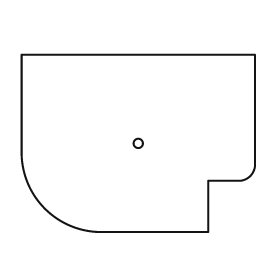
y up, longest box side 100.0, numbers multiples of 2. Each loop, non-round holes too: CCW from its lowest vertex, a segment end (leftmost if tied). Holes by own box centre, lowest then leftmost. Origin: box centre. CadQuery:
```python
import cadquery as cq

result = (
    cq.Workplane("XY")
    .moveTo(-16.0, -38.0)
    .lineTo(30.0, -38.0)
    .lineTo(30.0, -16.0)
    .lineTo(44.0, -16.0)
    .threePointArc((48.0, -14.0), (50.0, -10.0))
    .lineTo(50.0, 38.0)
    .lineTo(-50.0, 38.0)
    .lineTo(-50.0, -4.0)
    .threePointArc((-40.0, -28.0), (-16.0, -38.0))
    .close()
    .moveTo(0.0, 0.0)
    .circle(2.0)
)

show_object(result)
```